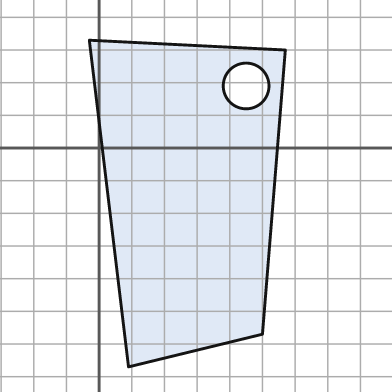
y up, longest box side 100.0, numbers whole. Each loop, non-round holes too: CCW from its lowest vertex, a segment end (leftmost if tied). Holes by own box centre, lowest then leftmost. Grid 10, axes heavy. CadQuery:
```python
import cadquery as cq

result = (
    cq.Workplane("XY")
    .moveTo(9.0, -67.0)
    .lineTo(50.0, -57.0)
    .lineTo(57.0, 30.0)
    .lineTo(-3.0, 33.0)
    .close()
    .moveTo(45.0, 19.0)
    .circle(7.0)
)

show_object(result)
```